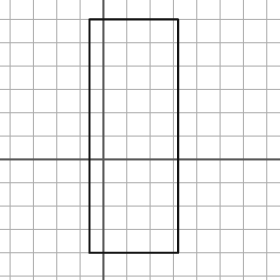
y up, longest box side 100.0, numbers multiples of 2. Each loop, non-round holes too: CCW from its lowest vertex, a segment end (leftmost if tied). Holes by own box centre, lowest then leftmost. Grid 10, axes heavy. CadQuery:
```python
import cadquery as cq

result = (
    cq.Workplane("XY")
    .moveTo(-6.0, -40.0)
    .lineTo(32.0, -40.0)
    .lineTo(32.0, 60.0)
    .lineTo(-6.0, 60.0)
    .close()
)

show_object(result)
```